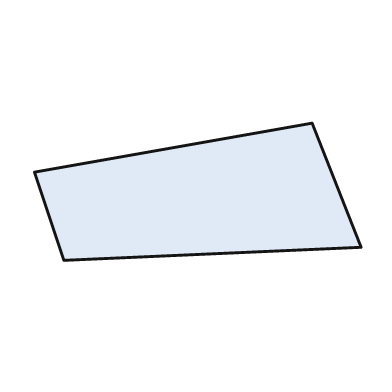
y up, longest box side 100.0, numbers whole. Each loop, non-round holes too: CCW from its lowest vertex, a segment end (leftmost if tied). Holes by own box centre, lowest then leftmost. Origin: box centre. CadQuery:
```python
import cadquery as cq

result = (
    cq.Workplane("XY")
    .moveTo(-41.0, -21.0)
    .lineTo(50.0, -17.0)
    .lineTo(35.0, 21.0)
    .lineTo(-50.0, 6.0)
    .close()
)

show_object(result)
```